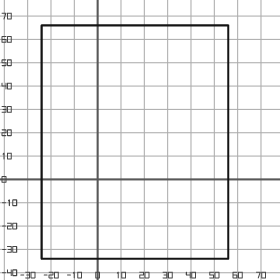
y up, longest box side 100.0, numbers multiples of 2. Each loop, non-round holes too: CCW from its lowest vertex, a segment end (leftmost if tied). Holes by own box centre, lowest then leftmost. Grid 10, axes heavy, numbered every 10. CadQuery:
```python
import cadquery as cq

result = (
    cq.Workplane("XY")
    .moveTo(-24.0, -34.0)
    .lineTo(56.0, -34.0)
    .lineTo(56.0, 66.0)
    .lineTo(-24.0, 66.0)
    .close()
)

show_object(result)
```